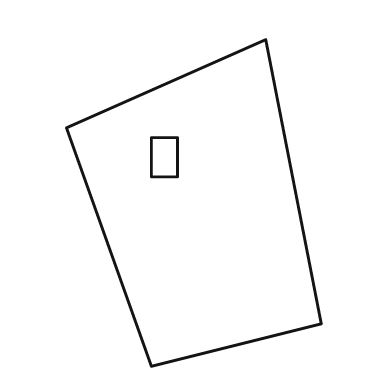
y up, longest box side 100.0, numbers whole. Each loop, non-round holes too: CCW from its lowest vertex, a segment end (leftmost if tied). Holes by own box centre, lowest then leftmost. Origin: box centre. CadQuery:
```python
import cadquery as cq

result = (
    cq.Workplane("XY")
    .moveTo(-13.0, -50.0)
    .lineTo(39.0, -37.0)
    .lineTo(22.0, 50.0)
    .lineTo(-39.0, 23.0)
    .close()
    .moveTo(-13.0, 8.0)
    .lineTo(-5.0, 8.0)
    .lineTo(-5.0, 20.0)
    .lineTo(-13.0, 20.0)
    .close()
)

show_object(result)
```